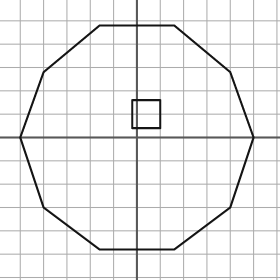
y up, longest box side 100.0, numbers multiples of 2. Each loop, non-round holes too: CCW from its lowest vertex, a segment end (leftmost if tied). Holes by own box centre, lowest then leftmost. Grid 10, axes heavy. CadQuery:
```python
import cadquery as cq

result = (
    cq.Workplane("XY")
    .moveTo(-16.0, -48.0)
    .lineTo(16.0, -48.0)
    .lineTo(40.0, -30.0)
    .lineTo(50.0, 0.0)
    .lineTo(40.0, 28.0)
    .lineTo(16.0, 48.0)
    .lineTo(-16.0, 48.0)
    .lineTo(-40.0, 28.0)
    .lineTo(-50.0, 0.0)
    .lineTo(-40.0, -30.0)
    .close()
    .moveTo(-2.0, 4.0)
    .lineTo(10.0, 4.0)
    .lineTo(10.0, 16.0)
    .lineTo(-2.0, 16.0)
    .close()
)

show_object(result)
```